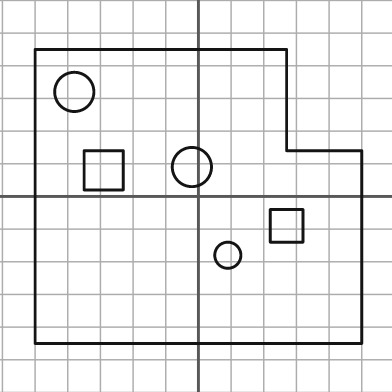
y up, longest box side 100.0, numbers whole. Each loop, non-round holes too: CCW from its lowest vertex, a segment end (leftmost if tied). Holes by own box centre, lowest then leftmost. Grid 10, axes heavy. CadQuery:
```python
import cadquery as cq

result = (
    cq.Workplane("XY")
    .moveTo(-50.0, -45.0)
    .lineTo(50.0, -45.0)
    .lineTo(50.0, 14.0)
    .lineTo(27.0, 14.0)
    .lineTo(27.0, 45.0)
    .lineTo(-50.0, 45.0)
    .close()
    .moveTo(9.0, -18.0)
    .circle(4.0)
    .moveTo(22.0, -14.0)
    .lineTo(32.0, -14.0)
    .lineTo(32.0, -4.0)
    .lineTo(22.0, -4.0)
    .close()
    .moveTo(-35.0, 2.0)
    .lineTo(-23.0, 2.0)
    .lineTo(-23.0, 14.0)
    .lineTo(-35.0, 14.0)
    .close()
    .moveTo(-2.0, 9.0)
    .circle(6.0)
    .moveTo(-38.0, 32.0)
    .circle(6.0)
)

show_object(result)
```